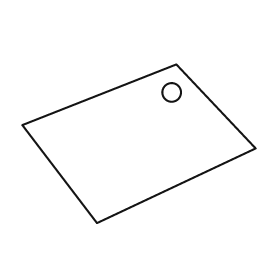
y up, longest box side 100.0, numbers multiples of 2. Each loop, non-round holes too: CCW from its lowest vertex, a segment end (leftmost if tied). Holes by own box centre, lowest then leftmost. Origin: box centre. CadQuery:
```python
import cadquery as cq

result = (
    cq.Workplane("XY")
    .moveTo(-18.0, -34.0)
    .lineTo(50.0, -2.0)
    .lineTo(16.0, 34.0)
    .lineTo(-50.0, 8.0)
    .close()
    .moveTo(14.0, 22.0)
    .circle(4.0)
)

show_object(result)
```